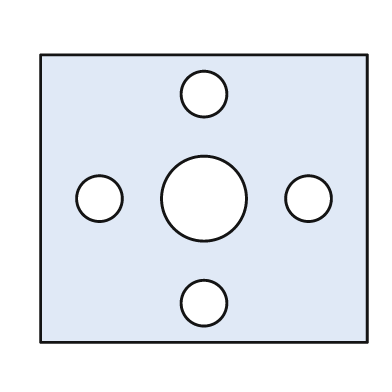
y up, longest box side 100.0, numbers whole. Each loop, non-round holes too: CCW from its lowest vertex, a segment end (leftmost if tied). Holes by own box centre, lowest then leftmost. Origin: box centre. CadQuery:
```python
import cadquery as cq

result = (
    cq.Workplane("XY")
    .moveTo(-50.0, -44.0)
    .lineTo(50.0, -44.0)
    .lineTo(50.0, 44.0)
    .lineTo(-50.0, 44.0)
    .close()
    .moveTo(0.0, -32.0)
    .circle(7.0)
    .moveTo(-32.0, 0.0)
    .circle(7.0)
    .moveTo(0.0, 0.0)
    .circle(13.0)
    .moveTo(32.0, 0.0)
    .circle(7.0)
    .moveTo(0.0, 32.0)
    .circle(7.0)
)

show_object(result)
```